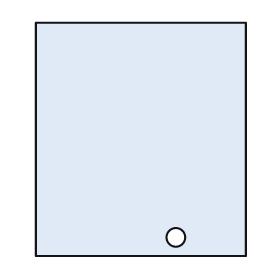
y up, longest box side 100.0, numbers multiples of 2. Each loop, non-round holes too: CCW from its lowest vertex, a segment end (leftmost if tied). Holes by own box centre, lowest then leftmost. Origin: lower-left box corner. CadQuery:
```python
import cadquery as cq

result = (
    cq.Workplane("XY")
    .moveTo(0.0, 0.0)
    .lineTo(90.0, 0.0)
    .lineTo(90.0, 100.0)
    .lineTo(0.0, 100.0)
    .close()
    .moveTo(60.0, 8.0)
    .circle(4.0)
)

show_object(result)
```